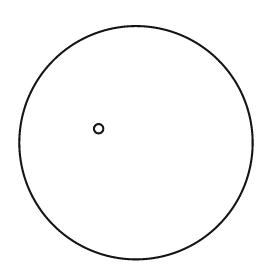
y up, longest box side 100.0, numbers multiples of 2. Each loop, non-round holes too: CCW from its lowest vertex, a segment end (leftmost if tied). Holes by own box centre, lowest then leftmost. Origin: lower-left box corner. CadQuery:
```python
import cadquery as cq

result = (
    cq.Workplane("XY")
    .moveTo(50.0, 50.0)
    .circle(50.0)
    .moveTo(34.0, 56.0)
    .circle(2.0)
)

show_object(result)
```